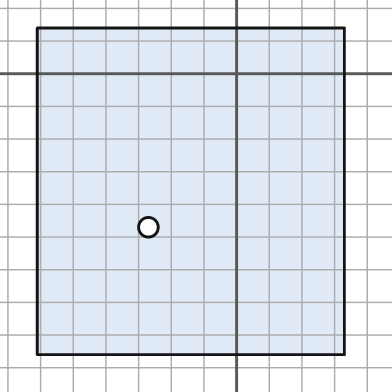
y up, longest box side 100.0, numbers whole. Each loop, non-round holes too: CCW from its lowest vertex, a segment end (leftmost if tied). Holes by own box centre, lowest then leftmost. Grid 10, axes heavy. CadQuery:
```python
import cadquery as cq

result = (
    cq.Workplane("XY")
    .moveTo(-61.0, -86.0)
    .lineTo(33.0, -86.0)
    .lineTo(33.0, 14.0)
    .lineTo(-61.0, 14.0)
    .close()
    .moveTo(-27.0, -47.0)
    .circle(3.0)
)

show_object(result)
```